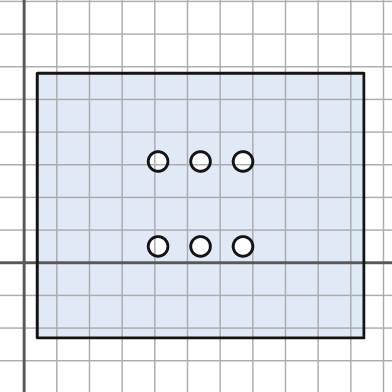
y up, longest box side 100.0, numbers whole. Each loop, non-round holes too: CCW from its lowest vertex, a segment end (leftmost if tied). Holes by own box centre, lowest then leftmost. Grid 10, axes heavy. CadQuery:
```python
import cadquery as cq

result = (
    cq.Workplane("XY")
    .moveTo(4.0, -23.0)
    .lineTo(104.0, -23.0)
    .lineTo(104.0, 58.0)
    .lineTo(4.0, 58.0)
    .close()
    .moveTo(41.0, 5.0)
    .circle(3.0)
    .moveTo(54.0, 5.0)
    .circle(3.0)
    .moveTo(67.0, 5.0)
    .circle(3.0)
    .moveTo(41.0, 31.0)
    .circle(3.0)
    .moveTo(54.0, 31.0)
    .circle(3.0)
    .moveTo(67.0, 31.0)
    .circle(3.0)
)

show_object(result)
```